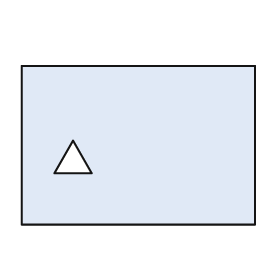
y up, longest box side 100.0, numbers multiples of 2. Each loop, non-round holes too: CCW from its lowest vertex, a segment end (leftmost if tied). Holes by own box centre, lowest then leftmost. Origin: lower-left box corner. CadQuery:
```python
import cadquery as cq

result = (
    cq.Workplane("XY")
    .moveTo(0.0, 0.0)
    .lineTo(100.0, 0.0)
    .lineTo(100.0, 68.0)
    .lineTo(0.0, 68.0)
    .close()
    .moveTo(14.0, 22.0)
    .lineTo(30.0, 22.0)
    .lineTo(22.0, 36.0)
    .close()
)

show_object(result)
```